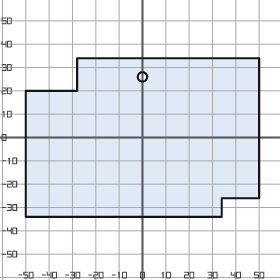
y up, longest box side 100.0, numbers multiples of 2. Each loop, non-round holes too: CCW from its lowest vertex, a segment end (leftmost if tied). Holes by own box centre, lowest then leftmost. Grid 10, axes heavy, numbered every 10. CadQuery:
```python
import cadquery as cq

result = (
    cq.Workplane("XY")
    .moveTo(-50.0, -34.0)
    .lineTo(34.0, -34.0)
    .lineTo(34.0, -26.0)
    .lineTo(50.0, -26.0)
    .lineTo(50.0, 34.0)
    .lineTo(-28.0, 34.0)
    .lineTo(-28.0, 20.0)
    .lineTo(-50.0, 20.0)
    .close()
    .moveTo(0.0, 26.0)
    .circle(2.0)
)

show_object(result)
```